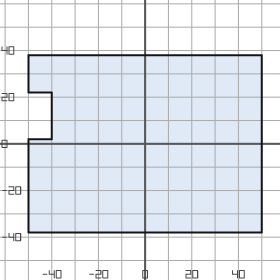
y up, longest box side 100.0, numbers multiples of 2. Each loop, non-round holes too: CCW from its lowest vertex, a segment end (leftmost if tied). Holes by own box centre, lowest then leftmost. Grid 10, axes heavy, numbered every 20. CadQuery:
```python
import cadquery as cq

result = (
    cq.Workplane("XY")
    .moveTo(-50.0, -38.0)
    .lineTo(50.0, -38.0)
    .lineTo(50.0, 38.0)
    .lineTo(-50.0, 38.0)
    .lineTo(-50.0, 22.0)
    .lineTo(-40.0, 22.0)
    .lineTo(-40.0, 2.0)
    .lineTo(-50.0, 2.0)
    .close()
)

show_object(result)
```